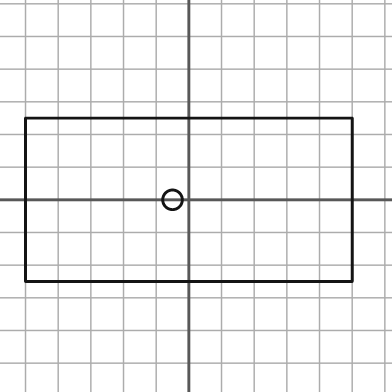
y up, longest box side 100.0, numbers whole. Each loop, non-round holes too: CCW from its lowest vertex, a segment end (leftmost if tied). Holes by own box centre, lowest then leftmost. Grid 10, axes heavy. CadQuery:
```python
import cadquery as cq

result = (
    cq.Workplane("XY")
    .moveTo(-50.0, -25.0)
    .lineTo(50.0, -25.0)
    .lineTo(50.0, 25.0)
    .lineTo(-50.0, 25.0)
    .close()
    .moveTo(-5.0, 0.0)
    .circle(3.0)
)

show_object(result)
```